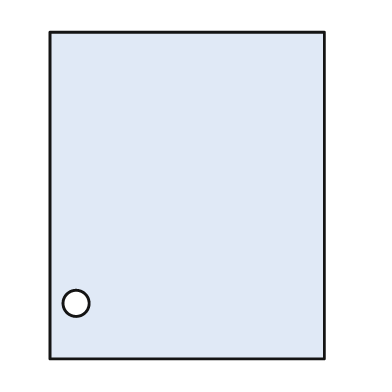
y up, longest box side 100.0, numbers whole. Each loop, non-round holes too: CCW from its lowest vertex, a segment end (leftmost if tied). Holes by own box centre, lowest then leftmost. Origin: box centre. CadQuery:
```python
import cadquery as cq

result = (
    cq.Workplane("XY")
    .moveTo(-42.0, -50.0)
    .lineTo(42.0, -50.0)
    .lineTo(42.0, 50.0)
    .lineTo(-42.0, 50.0)
    .close()
    .moveTo(-34.0, -33.0)
    .circle(4.0)
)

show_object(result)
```